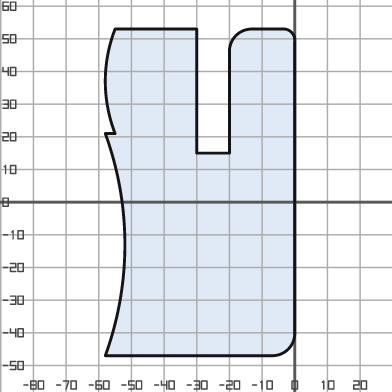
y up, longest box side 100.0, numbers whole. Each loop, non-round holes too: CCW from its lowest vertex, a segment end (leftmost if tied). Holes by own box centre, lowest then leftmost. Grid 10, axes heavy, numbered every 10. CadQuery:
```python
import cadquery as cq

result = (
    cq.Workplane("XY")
    .moveTo(-58.0, -47.0)
    .lineTo(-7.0, -47.0)
    .threePointArc((-2.0, -45.0), (0.0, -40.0))
    .lineTo(0.0, 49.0)
    .threePointArc((-1.0, 52.0), (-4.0, 53.0))
    .lineTo(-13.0, 53.0)
    .threePointArc((-18.0, 51.0), (-20.0, 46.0))
    .lineTo(-20.0, 15.0)
    .lineTo(-30.0, 15.0)
    .lineTo(-30.0, 53.0)
    .lineTo(-55.0, 53.0)
    .threePointArc((-58.0, 37.0), (-55.0, 21.0))
    .lineTo(-58.0, 21.0)
    .threePointArc((-52.0, -13.0), (-58.0, -47.0))
    .close()
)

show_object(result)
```